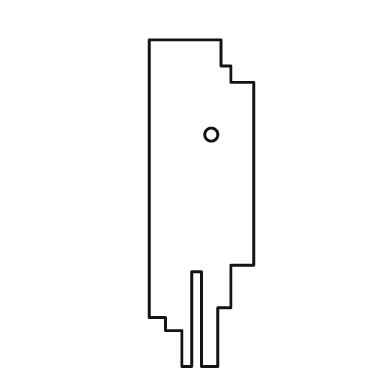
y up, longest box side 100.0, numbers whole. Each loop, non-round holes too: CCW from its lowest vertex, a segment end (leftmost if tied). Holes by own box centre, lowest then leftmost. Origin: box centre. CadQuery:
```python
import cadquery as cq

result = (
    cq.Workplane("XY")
    .moveTo(-6.0, -50.0)
    .lineTo(-3.0, -50.0)
    .lineTo(-3.0, -21.0)
    .lineTo(0.0, -21.0)
    .lineTo(0.0, -50.0)
    .lineTo(5.0, -50.0)
    .lineTo(5.0, -32.0)
    .lineTo(9.0, -32.0)
    .lineTo(9.0, -19.0)
    .lineTo(16.0, -19.0)
    .lineTo(16.0, 37.0)
    .lineTo(9.0, 37.0)
    .lineTo(9.0, 42.0)
    .lineTo(6.0, 42.0)
    .lineTo(6.0, 50.0)
    .lineTo(-16.0, 50.0)
    .lineTo(-16.0, -35.0)
    .lineTo(-11.0, -35.0)
    .lineTo(-11.0, -39.0)
    .lineTo(-6.0, -39.0)
    .close()
    .moveTo(3.0, 21.0)
    .circle(2.0)
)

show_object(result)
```